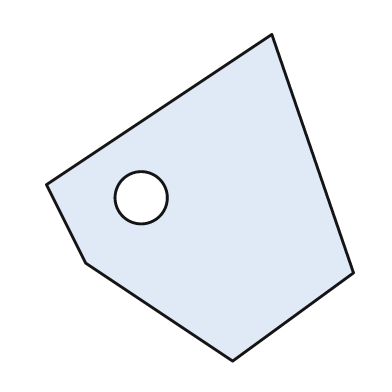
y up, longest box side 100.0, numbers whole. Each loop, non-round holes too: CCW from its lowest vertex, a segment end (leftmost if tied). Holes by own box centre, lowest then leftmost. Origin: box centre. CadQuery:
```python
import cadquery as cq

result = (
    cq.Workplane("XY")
    .moveTo(10.0, -50.0)
    .lineTo(47.0, -23.0)
    .lineTo(22.0, 50.0)
    .lineTo(-47.0, 4.0)
    .lineTo(-35.0, -20.0)
    .close()
    .moveTo(-18.0, 0.0)
    .circle(8.0)
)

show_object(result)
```